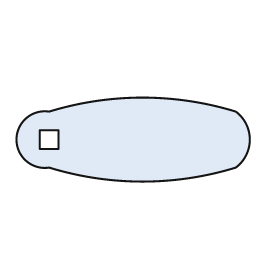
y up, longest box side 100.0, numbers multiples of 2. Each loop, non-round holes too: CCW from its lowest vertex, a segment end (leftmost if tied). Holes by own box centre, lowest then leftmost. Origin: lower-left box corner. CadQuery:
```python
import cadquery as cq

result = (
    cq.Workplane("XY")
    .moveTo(14.0, 6.0)
    .threePointArc((54.0, 0.0), (94.0, 6.0))
    .threePointArc((100.0, 18.0), (94.0, 30.0))
    .threePointArc((54.0, 36.0), (14.0, 30.0))
    .threePointArc((0.0, 18.0), (14.0, 6.0))
    .close()
    .moveTo(10.0, 14.0)
    .lineTo(18.0, 14.0)
    .lineTo(18.0, 22.0)
    .lineTo(10.0, 22.0)
    .close()
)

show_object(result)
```